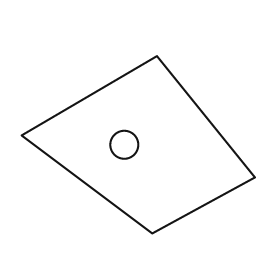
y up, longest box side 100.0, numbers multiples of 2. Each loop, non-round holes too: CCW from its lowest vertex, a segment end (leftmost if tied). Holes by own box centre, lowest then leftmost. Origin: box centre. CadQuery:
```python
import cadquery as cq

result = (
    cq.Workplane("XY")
    .moveTo(6.0, -38.0)
    .lineTo(50.0, -14.0)
    .lineTo(8.0, 38.0)
    .lineTo(-50.0, 4.0)
    .close()
    .moveTo(-6.0, 0.0)
    .circle(6.0)
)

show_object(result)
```